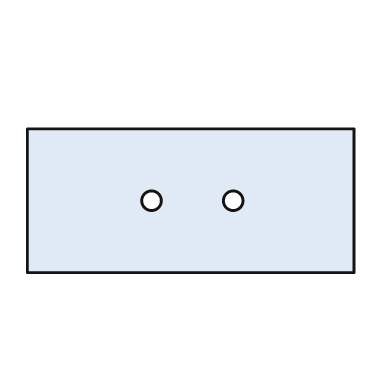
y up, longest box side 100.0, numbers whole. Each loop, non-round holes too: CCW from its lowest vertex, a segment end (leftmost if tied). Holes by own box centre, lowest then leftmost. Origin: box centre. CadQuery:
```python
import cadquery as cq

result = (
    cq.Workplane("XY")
    .moveTo(-50.0, -22.0)
    .lineTo(50.0, -22.0)
    .lineTo(50.0, 22.0)
    .lineTo(-50.0, 22.0)
    .close()
    .moveTo(-12.0, 0.0)
    .circle(3.0)
    .moveTo(13.0, 0.0)
    .circle(3.0)
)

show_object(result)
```